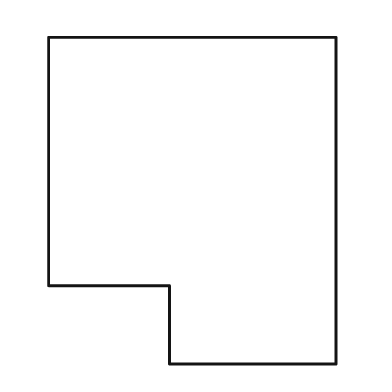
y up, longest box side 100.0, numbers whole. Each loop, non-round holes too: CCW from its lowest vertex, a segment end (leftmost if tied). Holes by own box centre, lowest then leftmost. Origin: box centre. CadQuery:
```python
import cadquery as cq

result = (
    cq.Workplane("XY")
    .moveTo(-7.0, -50.0)
    .lineTo(44.0, -50.0)
    .lineTo(44.0, 50.0)
    .lineTo(-44.0, 50.0)
    .lineTo(-44.0, -26.0)
    .lineTo(-7.0, -26.0)
    .close()
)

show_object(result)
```